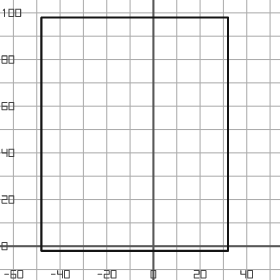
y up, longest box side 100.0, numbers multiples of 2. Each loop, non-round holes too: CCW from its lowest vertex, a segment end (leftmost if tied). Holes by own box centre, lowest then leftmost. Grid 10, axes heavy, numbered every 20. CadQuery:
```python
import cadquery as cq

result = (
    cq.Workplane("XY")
    .moveTo(-48.0, -2.0)
    .lineTo(32.0, -2.0)
    .lineTo(32.0, 98.0)
    .lineTo(-48.0, 98.0)
    .close()
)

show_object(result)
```